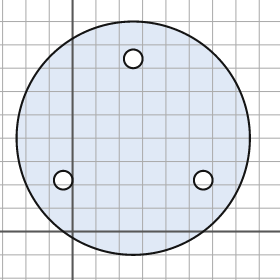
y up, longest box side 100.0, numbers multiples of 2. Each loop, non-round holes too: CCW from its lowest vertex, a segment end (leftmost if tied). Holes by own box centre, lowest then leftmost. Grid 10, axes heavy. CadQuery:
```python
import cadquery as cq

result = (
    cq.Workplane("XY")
    .moveTo(26.0, 40.0)
    .circle(50.0)
    .moveTo(-4.0, 22.0)
    .circle(4.0)
    .moveTo(56.0, 22.0)
    .circle(4.0)
    .moveTo(26.0, 74.0)
    .circle(4.0)
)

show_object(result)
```